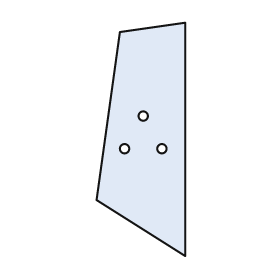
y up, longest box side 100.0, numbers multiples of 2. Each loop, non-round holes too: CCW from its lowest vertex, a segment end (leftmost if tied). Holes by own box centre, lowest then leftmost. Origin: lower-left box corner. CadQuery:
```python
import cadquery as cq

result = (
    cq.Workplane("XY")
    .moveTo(38.0, 0.0)
    .lineTo(38.0, 100.0)
    .lineTo(10.0, 96.0)
    .lineTo(0.0, 24.0)
    .close()
    .moveTo(12.0, 46.0)
    .circle(2.0)
    .moveTo(28.0, 46.0)
    .circle(2.0)
    .moveTo(20.0, 60.0)
    .circle(2.0)
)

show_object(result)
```